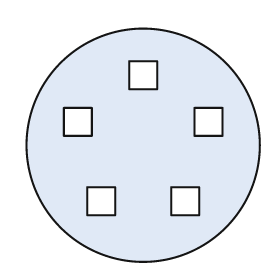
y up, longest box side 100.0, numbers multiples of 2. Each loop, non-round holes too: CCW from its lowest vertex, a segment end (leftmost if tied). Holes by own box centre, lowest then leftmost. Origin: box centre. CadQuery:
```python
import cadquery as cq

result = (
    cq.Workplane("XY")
    .moveTo(0.0, 0.0)
    .circle(50.0)
    .moveTo(-24.0, -30.0)
    .lineTo(-12.0, -30.0)
    .lineTo(-12.0, -18.0)
    .lineTo(-24.0, -18.0)
    .close()
    .moveTo(12.0, -30.0)
    .lineTo(24.0, -30.0)
    .lineTo(24.0, -18.0)
    .lineTo(12.0, -18.0)
    .close()
    .moveTo(-34.0, 4.0)
    .lineTo(-22.0, 4.0)
    .lineTo(-22.0, 16.0)
    .lineTo(-34.0, 16.0)
    .close()
    .moveTo(22.0, 4.0)
    .lineTo(34.0, 4.0)
    .lineTo(34.0, 16.0)
    .lineTo(22.0, 16.0)
    .close()
    .moveTo(-6.0, 24.0)
    .lineTo(6.0, 24.0)
    .lineTo(6.0, 36.0)
    .lineTo(-6.0, 36.0)
    .close()
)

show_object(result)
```